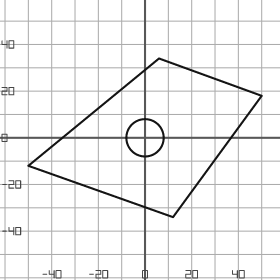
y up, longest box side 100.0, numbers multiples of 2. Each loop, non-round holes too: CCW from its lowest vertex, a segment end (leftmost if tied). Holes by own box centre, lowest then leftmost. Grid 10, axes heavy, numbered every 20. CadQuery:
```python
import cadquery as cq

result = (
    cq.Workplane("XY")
    .moveTo(12.0, -34.0)
    .lineTo(50.0, 18.0)
    .lineTo(6.0, 34.0)
    .lineTo(-50.0, -12.0)
    .close()
    .moveTo(0.0, 0.0)
    .circle(8.0)
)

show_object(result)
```